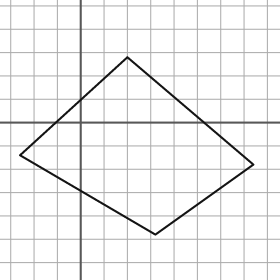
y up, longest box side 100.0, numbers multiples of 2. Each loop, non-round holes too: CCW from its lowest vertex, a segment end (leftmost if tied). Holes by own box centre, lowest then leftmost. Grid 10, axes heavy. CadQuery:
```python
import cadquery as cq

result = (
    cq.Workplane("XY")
    .moveTo(32.0, -48.0)
    .lineTo(74.0, -18.0)
    .lineTo(20.0, 28.0)
    .lineTo(-26.0, -14.0)
    .close()
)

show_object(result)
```